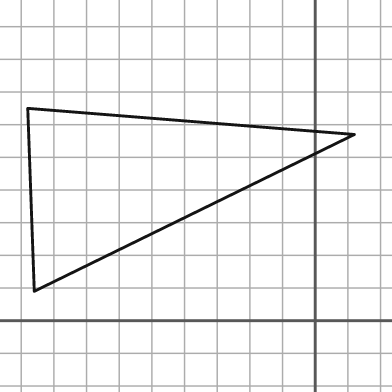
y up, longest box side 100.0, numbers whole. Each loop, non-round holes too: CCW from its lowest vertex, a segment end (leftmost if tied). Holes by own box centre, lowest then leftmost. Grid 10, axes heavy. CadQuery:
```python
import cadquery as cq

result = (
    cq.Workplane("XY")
    .moveTo(-86.0, 9.0)
    .lineTo(12.0, 57.0)
    .lineTo(-88.0, 65.0)
    .close()
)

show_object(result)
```